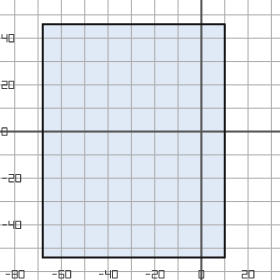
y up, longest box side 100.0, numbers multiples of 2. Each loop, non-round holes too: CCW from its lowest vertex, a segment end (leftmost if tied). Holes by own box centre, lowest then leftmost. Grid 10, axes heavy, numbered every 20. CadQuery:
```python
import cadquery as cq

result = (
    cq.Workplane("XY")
    .moveTo(-68.0, -54.0)
    .lineTo(10.0, -54.0)
    .lineTo(10.0, 46.0)
    .lineTo(-68.0, 46.0)
    .close()
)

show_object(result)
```